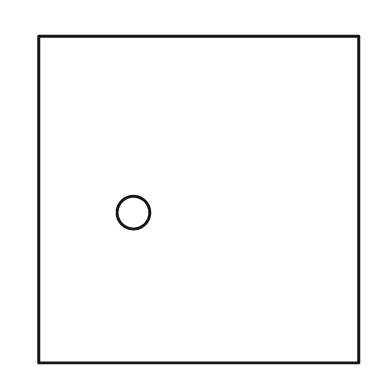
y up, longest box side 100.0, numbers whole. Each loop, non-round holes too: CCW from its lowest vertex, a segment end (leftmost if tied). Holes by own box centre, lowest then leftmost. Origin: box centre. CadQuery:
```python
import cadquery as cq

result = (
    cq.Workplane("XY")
    .moveTo(-49.0, -50.0)
    .lineTo(49.0, -50.0)
    .lineTo(49.0, 50.0)
    .lineTo(-49.0, 50.0)
    .close()
    .moveTo(-20.0, -4.0)
    .circle(5.0)
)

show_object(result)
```